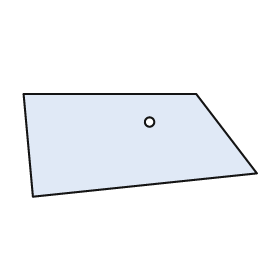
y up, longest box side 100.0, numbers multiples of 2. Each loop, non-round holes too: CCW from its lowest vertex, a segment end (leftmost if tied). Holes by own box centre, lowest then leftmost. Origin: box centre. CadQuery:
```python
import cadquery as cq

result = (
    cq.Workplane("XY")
    .moveTo(-46.0, -22.0)
    .lineTo(50.0, -12.0)
    .lineTo(24.0, 22.0)
    .lineTo(-50.0, 22.0)
    .close()
    .moveTo(4.0, 10.0)
    .circle(2.0)
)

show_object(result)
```